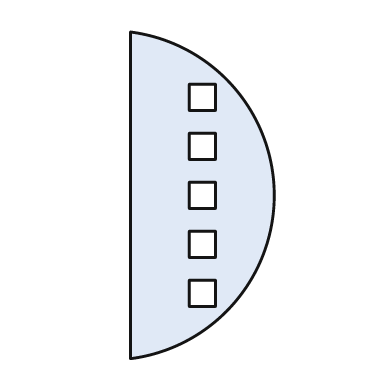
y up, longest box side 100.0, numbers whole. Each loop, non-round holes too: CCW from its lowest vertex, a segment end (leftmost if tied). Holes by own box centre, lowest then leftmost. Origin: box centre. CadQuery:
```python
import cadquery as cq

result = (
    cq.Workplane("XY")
    .moveTo(-22.0, -50.0)
    .threePointArc((22.0, 0.0), (-22.0, 50.0))
    .close()
    .moveTo(-4.0, -34.0)
    .lineTo(4.0, -34.0)
    .lineTo(4.0, -26.0)
    .lineTo(-4.0, -26.0)
    .close()
    .moveTo(-4.0, -19.0)
    .lineTo(4.0, -19.0)
    .lineTo(4.0, -11.0)
    .lineTo(-4.0, -11.0)
    .close()
    .moveTo(-4.0, -4.0)
    .lineTo(4.0, -4.0)
    .lineTo(4.0, 4.0)
    .lineTo(-4.0, 4.0)
    .close()
    .moveTo(-4.0, 11.0)
    .lineTo(4.0, 11.0)
    .lineTo(4.0, 19.0)
    .lineTo(-4.0, 19.0)
    .close()
    .moveTo(-4.0, 26.0)
    .lineTo(4.0, 26.0)
    .lineTo(4.0, 34.0)
    .lineTo(-4.0, 34.0)
    .close()
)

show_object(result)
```